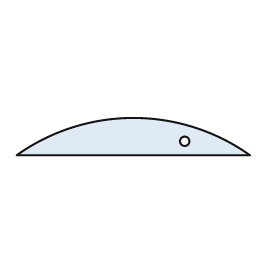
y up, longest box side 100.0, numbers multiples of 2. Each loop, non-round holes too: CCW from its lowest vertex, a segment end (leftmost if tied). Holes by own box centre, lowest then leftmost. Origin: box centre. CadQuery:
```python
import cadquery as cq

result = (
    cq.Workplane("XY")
    .moveTo(-50.0, -8.0)
    .lineTo(50.0, -8.0)
    .threePointArc((0.0, 8.0), (-50.0, -8.0))
    .close()
    .moveTo(22.0, -2.0)
    .circle(2.0)
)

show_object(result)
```